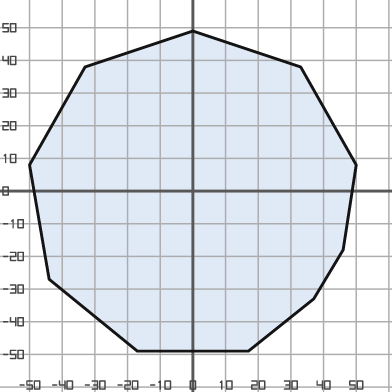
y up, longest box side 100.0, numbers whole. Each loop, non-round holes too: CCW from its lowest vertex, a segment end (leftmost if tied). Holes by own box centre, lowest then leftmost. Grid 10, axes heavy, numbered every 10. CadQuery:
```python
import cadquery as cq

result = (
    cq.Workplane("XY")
    .moveTo(-17.0, -49.0)
    .lineTo(17.0, -49.0)
    .lineTo(37.0, -33.0)
    .lineTo(46.0, -18.0)
    .lineTo(50.0, 8.0)
    .lineTo(33.0, 38.0)
    .lineTo(0.0, 49.0)
    .lineTo(-33.0, 38.0)
    .lineTo(-50.0, 8.0)
    .lineTo(-44.0, -27.0)
    .close()
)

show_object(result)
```